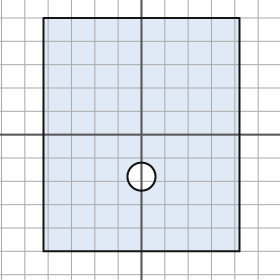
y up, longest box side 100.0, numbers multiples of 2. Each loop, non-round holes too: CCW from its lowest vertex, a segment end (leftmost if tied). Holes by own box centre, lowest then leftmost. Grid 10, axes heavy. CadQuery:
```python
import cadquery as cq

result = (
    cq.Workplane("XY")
    .moveTo(-42.0, -50.0)
    .lineTo(42.0, -50.0)
    .lineTo(42.0, 50.0)
    .lineTo(-42.0, 50.0)
    .close()
    .moveTo(0.0, -18.0)
    .circle(6.0)
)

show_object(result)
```